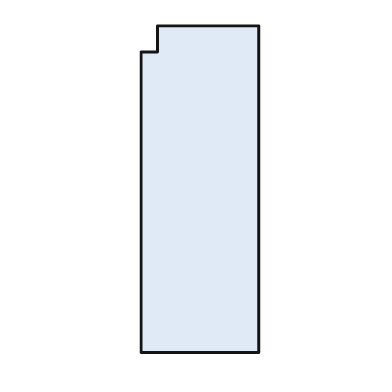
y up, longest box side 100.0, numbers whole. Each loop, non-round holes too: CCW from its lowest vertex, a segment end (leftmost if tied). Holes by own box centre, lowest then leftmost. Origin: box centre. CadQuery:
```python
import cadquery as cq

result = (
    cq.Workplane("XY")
    .moveTo(-18.0, -50.0)
    .lineTo(18.0, -50.0)
    .lineTo(18.0, 50.0)
    .lineTo(-13.0, 50.0)
    .lineTo(-13.0, 42.0)
    .lineTo(-18.0, 42.0)
    .close()
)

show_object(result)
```